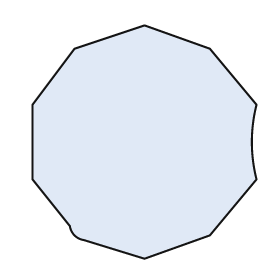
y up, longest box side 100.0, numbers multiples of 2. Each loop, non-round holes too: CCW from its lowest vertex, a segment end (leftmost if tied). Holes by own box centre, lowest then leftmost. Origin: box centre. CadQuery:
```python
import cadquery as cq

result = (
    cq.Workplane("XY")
    .moveTo(0.0, -50.0)
    .lineTo(28.0, -40.0)
    .lineTo(48.0, -16.0)
    .threePointArc((46.0, 0.0), (48.0, 16.0))
    .lineTo(28.0, 40.0)
    .lineTo(0.0, 50.0)
    .lineTo(-30.0, 40.0)
    .lineTo(-48.0, 16.0)
    .lineTo(-48.0, -16.0)
    .lineTo(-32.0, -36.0)
    .threePointArc((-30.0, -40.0), (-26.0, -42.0))
    .close()
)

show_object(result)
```